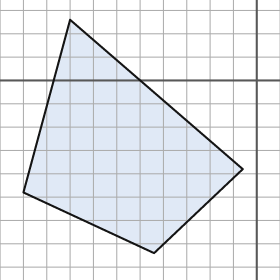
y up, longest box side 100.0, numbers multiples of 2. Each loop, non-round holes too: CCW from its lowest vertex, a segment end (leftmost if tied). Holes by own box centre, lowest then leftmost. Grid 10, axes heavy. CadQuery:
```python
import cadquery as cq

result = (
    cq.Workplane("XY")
    .moveTo(-44.0, -74.0)
    .lineTo(-6.0, -38.0)
    .lineTo(-80.0, 26.0)
    .lineTo(-100.0, -48.0)
    .close()
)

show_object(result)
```